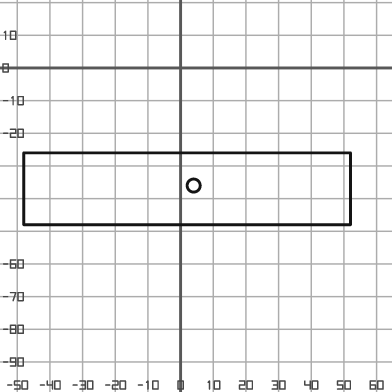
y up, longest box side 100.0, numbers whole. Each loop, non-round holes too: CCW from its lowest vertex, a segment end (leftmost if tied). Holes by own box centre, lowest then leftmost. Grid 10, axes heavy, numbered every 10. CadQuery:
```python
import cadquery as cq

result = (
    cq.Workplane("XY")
    .moveTo(-48.0, -48.0)
    .lineTo(52.0, -48.0)
    .lineTo(52.0, -26.0)
    .lineTo(-48.0, -26.0)
    .close()
    .moveTo(4.0, -36.0)
    .circle(2.0)
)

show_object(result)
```